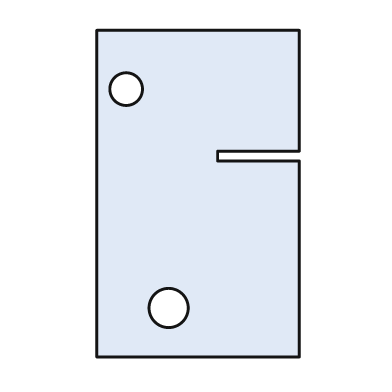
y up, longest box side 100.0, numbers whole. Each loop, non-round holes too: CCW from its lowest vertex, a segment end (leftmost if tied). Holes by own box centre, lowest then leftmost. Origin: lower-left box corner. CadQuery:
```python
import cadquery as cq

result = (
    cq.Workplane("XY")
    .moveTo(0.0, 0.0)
    .lineTo(62.0, 0.0)
    .lineTo(62.0, 60.0)
    .lineTo(37.0, 60.0)
    .lineTo(37.0, 63.0)
    .lineTo(62.0, 63.0)
    .lineTo(62.0, 100.0)
    .lineTo(0.0, 100.0)
    .close()
    .moveTo(22.0, 15.0)
    .circle(6.0)
    .moveTo(9.0, 82.0)
    .circle(5.0)
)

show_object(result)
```